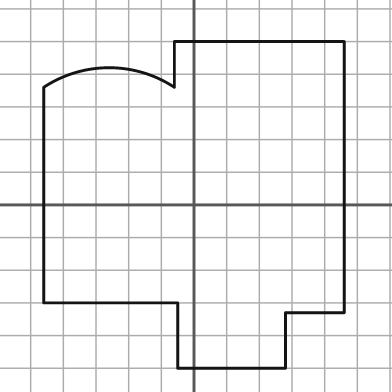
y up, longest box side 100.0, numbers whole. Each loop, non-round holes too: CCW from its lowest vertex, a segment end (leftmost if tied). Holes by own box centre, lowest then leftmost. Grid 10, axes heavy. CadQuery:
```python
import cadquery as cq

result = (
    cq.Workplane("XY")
    .moveTo(-5.0, -50.0)
    .lineTo(28.0, -50.0)
    .lineTo(28.0, -33.0)
    .lineTo(46.0, -33.0)
    .lineTo(46.0, 50.0)
    .lineTo(-6.0, 50.0)
    .lineTo(-6.0, 36.0)
    .threePointArc((-26.0, 42.0), (-46.0, 36.0))
    .lineTo(-46.0, -30.0)
    .lineTo(-5.0, -30.0)
    .close()
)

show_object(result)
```